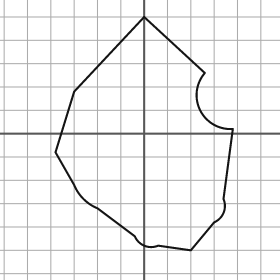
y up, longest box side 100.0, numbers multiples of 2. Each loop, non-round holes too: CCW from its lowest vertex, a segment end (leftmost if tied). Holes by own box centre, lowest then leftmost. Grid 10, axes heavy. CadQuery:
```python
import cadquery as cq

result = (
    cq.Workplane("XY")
    .moveTo(20.0, -50.0)
    .lineTo(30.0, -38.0)
    .threePointArc((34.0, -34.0), (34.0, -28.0))
    .lineTo(38.0, 2.0)
    .threePointArc((24.0, 10.0), (26.0, 26.0))
    .lineTo(0.0, 50.0)
    .lineTo(-30.0, 18.0)
    .lineTo(-38.0, -8.0)
    .lineTo(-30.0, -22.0)
    .threePointArc((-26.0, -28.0), (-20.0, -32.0))
    .lineTo(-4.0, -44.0)
    .threePointArc((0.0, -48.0), (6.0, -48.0))
    .close()
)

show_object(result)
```